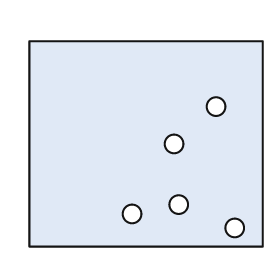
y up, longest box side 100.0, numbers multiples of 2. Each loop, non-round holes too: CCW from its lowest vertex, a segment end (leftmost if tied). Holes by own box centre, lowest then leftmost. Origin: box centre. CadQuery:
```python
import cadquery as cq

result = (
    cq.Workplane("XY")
    .moveTo(-50.0, -44.0)
    .lineTo(50.0, -44.0)
    .lineTo(50.0, 44.0)
    .lineTo(-50.0, 44.0)
    .close()
    .moveTo(38.0, -36.0)
    .circle(4.0)
    .moveTo(-6.0, -30.0)
    .circle(4.0)
    .moveTo(14.0, -26.0)
    .circle(4.0)
    .moveTo(12.0, 0.0)
    .circle(4.0)
    .moveTo(30.0, 16.0)
    .circle(4.0)
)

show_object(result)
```